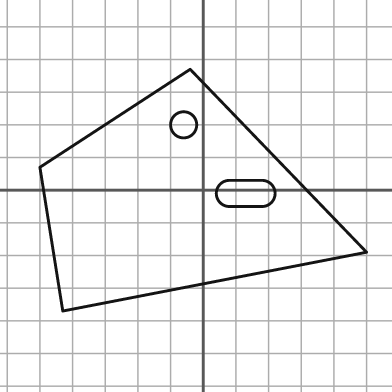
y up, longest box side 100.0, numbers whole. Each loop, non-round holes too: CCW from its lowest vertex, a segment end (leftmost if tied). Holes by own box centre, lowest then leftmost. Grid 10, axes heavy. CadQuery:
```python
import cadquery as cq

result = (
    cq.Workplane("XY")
    .moveTo(-43.0, -37.0)
    .lineTo(50.0, -19.0)
    .lineTo(-4.0, 37.0)
    .lineTo(-50.0, 7.0)
    .close()
    .moveTo(8.0, -5.0)
    .lineTo(18.0, -5.0)
    .threePointArc((22.0, -1.0), (18.0, 3.0))
    .lineTo(8.0, 3.0)
    .threePointArc((4.0, -1.0), (8.0, -5.0))
    .close()
    .moveTo(-6.0, 20.0)
    .circle(4.0)
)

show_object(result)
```